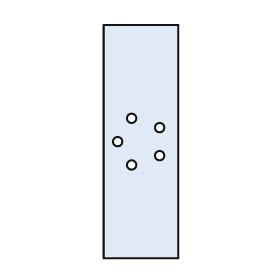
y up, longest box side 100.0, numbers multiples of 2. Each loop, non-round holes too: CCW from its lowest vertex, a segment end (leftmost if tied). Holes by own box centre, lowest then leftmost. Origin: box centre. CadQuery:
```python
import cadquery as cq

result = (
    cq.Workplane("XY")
    .moveTo(-16.0, -50.0)
    .lineTo(16.0, -50.0)
    .lineTo(16.0, 50.0)
    .lineTo(-16.0, 50.0)
    .close()
    .moveTo(-4.0, -10.0)
    .circle(2.0)
    .moveTo(8.0, -6.0)
    .circle(2.0)
    .moveTo(-10.0, 0.0)
    .circle(2.0)
    .moveTo(8.0, 6.0)
    .circle(2.0)
    .moveTo(-4.0, 10.0)
    .circle(2.0)
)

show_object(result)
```